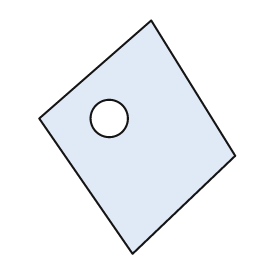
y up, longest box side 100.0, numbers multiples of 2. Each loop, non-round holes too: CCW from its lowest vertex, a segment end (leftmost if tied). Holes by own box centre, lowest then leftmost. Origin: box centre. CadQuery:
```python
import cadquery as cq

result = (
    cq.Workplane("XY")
    .moveTo(-2.0, -50.0)
    .lineTo(42.0, -8.0)
    .lineTo(6.0, 50.0)
    .lineTo(-42.0, 8.0)
    .close()
    .moveTo(-12.0, 8.0)
    .circle(8.0)
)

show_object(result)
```